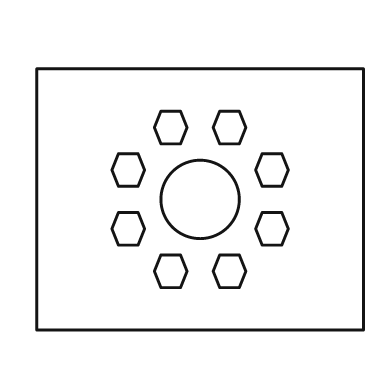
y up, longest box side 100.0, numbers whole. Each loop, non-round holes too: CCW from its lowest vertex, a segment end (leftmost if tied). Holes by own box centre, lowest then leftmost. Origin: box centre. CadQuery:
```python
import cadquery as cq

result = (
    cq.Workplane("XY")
    .moveTo(-50.0, -40.0)
    .lineTo(50.0, -40.0)
    .lineTo(50.0, 40.0)
    .lineTo(-50.0, 40.0)
    .close()
    .moveTo(-12.0, -27.0)
    .lineTo(-6.0, -27.0)
    .lineTo(-4.0, -22.0)
    .lineTo(-6.0, -17.0)
    .lineTo(-12.0, -17.0)
    .lineTo(-14.0, -22.0)
    .close()
    .moveTo(6.0, -27.0)
    .lineTo(12.0, -27.0)
    .lineTo(14.0, -22.0)
    .lineTo(12.0, -17.0)
    .lineTo(6.0, -17.0)
    .lineTo(4.0, -22.0)
    .close()
    .moveTo(-25.0, -14.0)
    .lineTo(-19.0, -14.0)
    .lineTo(-17.0, -9.0)
    .lineTo(-19.0, -4.0)
    .lineTo(-25.0, -4.0)
    .lineTo(-27.0, -9.0)
    .close()
    .moveTo(19.0, -14.0)
    .lineTo(25.0, -14.0)
    .lineTo(27.0, -9.0)
    .lineTo(25.0, -4.0)
    .lineTo(19.0, -4.0)
    .lineTo(17.0, -9.0)
    .close()
    .moveTo(0.0, 0.0)
    .circle(12.0)
    .moveTo(-25.0, 4.0)
    .lineTo(-19.0, 4.0)
    .lineTo(-17.0, 9.0)
    .lineTo(-19.0, 14.0)
    .lineTo(-25.0, 14.0)
    .lineTo(-27.0, 9.0)
    .close()
    .moveTo(19.0, 4.0)
    .lineTo(25.0, 4.0)
    .lineTo(27.0, 9.0)
    .lineTo(25.0, 14.0)
    .lineTo(19.0, 14.0)
    .lineTo(17.0, 9.0)
    .close()
    .moveTo(-12.0, 17.0)
    .lineTo(-6.0, 17.0)
    .lineTo(-4.0, 22.0)
    .lineTo(-6.0, 27.0)
    .lineTo(-12.0, 27.0)
    .lineTo(-14.0, 22.0)
    .close()
    .moveTo(6.0, 17.0)
    .lineTo(12.0, 17.0)
    .lineTo(14.0, 22.0)
    .lineTo(12.0, 27.0)
    .lineTo(6.0, 27.0)
    .lineTo(4.0, 22.0)
    .close()
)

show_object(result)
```